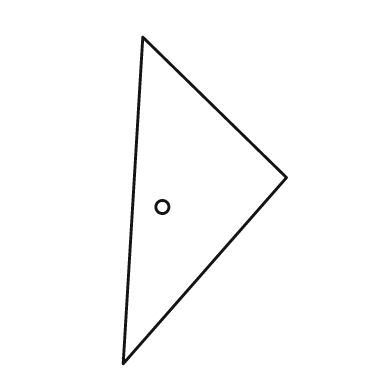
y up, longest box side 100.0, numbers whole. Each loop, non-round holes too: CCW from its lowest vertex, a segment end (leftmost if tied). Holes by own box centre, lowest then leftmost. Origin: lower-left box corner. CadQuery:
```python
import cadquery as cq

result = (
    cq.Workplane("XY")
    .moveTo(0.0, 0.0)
    .lineTo(50.0, 57.0)
    .lineTo(6.0, 100.0)
    .close()
    .moveTo(12.0, 48.0)
    .circle(2.0)
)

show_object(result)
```